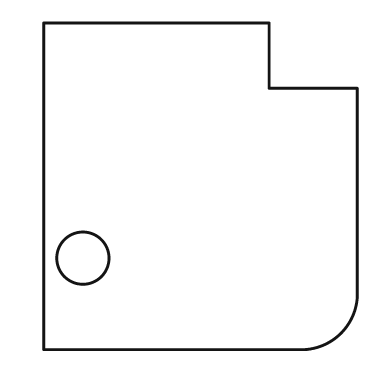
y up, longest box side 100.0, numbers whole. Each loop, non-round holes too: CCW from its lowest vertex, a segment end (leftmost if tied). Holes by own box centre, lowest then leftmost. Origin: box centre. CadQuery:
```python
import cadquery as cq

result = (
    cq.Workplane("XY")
    .moveTo(-48.0, -50.0)
    .lineTo(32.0, -50.0)
    .threePointArc((43.0, -45.0), (48.0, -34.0))
    .lineTo(48.0, 30.0)
    .lineTo(21.0, 30.0)
    .lineTo(21.0, 50.0)
    .lineTo(-48.0, 50.0)
    .close()
    .moveTo(-36.0, -22.0)
    .circle(8.0)
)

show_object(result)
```